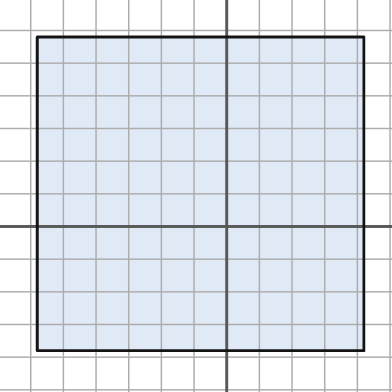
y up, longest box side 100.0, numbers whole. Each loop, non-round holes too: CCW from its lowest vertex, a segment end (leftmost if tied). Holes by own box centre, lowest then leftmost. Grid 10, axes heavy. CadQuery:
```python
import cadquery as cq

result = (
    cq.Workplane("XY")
    .moveTo(-58.0, -38.0)
    .lineTo(42.0, -38.0)
    .lineTo(42.0, 58.0)
    .lineTo(-58.0, 58.0)
    .close()
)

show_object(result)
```